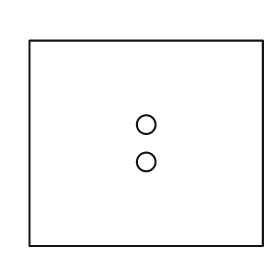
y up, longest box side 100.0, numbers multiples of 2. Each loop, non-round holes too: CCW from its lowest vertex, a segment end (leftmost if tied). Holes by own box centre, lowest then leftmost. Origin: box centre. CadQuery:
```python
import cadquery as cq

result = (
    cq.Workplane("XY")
    .moveTo(-50.0, -44.0)
    .lineTo(50.0, -44.0)
    .lineTo(50.0, 44.0)
    .lineTo(-50.0, 44.0)
    .close()
    .moveTo(0.0, -8.0)
    .circle(4.0)
    .moveTo(0.0, 8.0)
    .circle(4.0)
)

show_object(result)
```